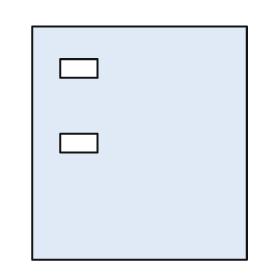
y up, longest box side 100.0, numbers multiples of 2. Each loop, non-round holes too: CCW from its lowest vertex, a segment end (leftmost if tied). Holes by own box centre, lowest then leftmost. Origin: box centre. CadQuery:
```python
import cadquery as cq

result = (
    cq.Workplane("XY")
    .moveTo(-46.0, -50.0)
    .lineTo(46.0, -50.0)
    .lineTo(46.0, 50.0)
    .lineTo(-46.0, 50.0)
    .close()
    .moveTo(-34.0, -4.0)
    .lineTo(-18.0, -4.0)
    .lineTo(-18.0, 4.0)
    .lineTo(-34.0, 4.0)
    .close()
    .moveTo(-34.0, 28.0)
    .lineTo(-18.0, 28.0)
    .lineTo(-18.0, 36.0)
    .lineTo(-34.0, 36.0)
    .close()
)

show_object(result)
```